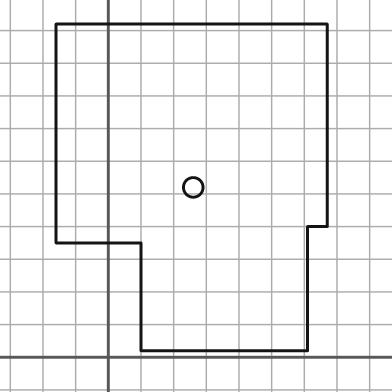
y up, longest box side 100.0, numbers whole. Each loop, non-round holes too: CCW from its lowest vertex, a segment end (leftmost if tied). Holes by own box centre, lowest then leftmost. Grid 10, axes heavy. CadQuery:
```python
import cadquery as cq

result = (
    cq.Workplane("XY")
    .moveTo(10.0, 2.0)
    .lineTo(61.0, 2.0)
    .lineTo(61.0, 40.0)
    .lineTo(67.0, 40.0)
    .lineTo(67.0, 102.0)
    .lineTo(-16.0, 102.0)
    .lineTo(-16.0, 35.0)
    .lineTo(10.0, 35.0)
    .close()
    .moveTo(26.0, 52.0)
    .circle(3.0)
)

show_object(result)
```